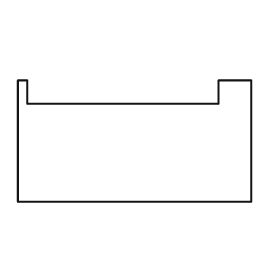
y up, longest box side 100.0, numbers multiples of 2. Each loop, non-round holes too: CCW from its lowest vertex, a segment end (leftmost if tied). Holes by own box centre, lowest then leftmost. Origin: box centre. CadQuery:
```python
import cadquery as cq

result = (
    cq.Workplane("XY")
    .moveTo(-50.0, -26.0)
    .lineTo(50.0, -26.0)
    .lineTo(50.0, 26.0)
    .lineTo(36.0, 26.0)
    .lineTo(36.0, 16.0)
    .lineTo(-46.0, 16.0)
    .lineTo(-46.0, 26.0)
    .lineTo(-50.0, 26.0)
    .close()
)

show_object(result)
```